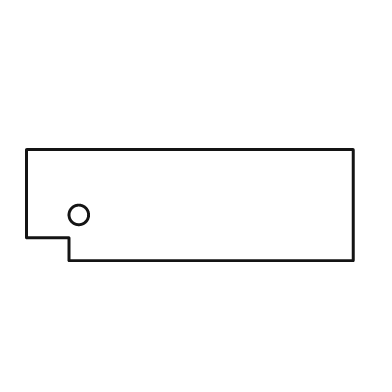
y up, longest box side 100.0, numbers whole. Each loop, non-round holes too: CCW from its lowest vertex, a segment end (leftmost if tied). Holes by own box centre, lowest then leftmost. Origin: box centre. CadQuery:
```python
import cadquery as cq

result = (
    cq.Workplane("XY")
    .moveTo(-37.0, -17.0)
    .lineTo(50.0, -17.0)
    .lineTo(50.0, 17.0)
    .lineTo(-50.0, 17.0)
    .lineTo(-50.0, -10.0)
    .lineTo(-37.0, -10.0)
    .close()
    .moveTo(-34.0, -3.0)
    .circle(3.0)
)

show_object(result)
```